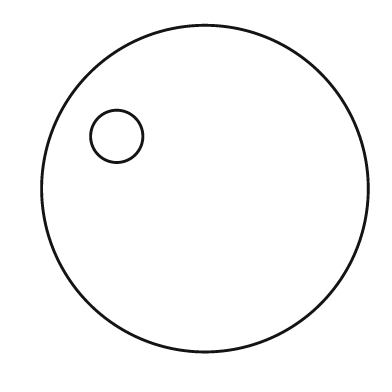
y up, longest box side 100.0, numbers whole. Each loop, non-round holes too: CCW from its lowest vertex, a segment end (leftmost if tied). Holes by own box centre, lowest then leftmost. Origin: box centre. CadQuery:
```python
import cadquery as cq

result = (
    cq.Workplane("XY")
    .moveTo(0.0, 0.0)
    .circle(50.0)
    .moveTo(-27.0, 16.0)
    .circle(8.0)
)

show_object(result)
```